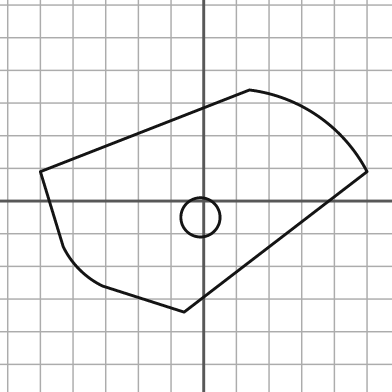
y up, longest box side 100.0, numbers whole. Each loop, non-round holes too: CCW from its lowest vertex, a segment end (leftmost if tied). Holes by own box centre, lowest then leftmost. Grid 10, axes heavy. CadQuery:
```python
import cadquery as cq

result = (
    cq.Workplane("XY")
    .moveTo(-6.0, -34.0)
    .lineTo(50.0, 9.0)
    .threePointArc((35.0, 26.0), (14.0, 34.0))
    .lineTo(-50.0, 9.0)
    .lineTo(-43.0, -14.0)
    .threePointArc((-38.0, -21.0), (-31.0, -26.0))
    .close()
    .moveTo(-1.0, -5.0)
    .circle(6.0)
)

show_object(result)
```